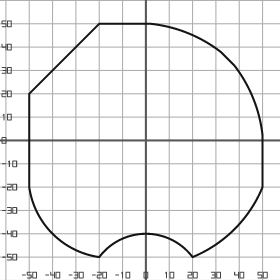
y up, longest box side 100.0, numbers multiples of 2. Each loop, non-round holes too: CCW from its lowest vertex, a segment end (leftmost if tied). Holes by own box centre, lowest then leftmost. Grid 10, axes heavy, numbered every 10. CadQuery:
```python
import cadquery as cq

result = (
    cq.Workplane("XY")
    .moveTo(-20.0, -50.0)
    .threePointArc((0.0, -40.0), (20.0, -50.0))
    .threePointArc((38.0, -38.0), (50.0, -20.0))
    .lineTo(50.0, 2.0)
    .threePointArc((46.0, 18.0), (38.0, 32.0))
    .lineTo(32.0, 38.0)
    .threePointArc((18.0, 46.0), (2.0, 50.0))
    .lineTo(-20.0, 50.0)
    .lineTo(-50.0, 20.0)
    .lineTo(-50.0, -20.0)
    .threePointArc((-40.0, -40.0), (-20.0, -50.0))
    .close()
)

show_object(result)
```